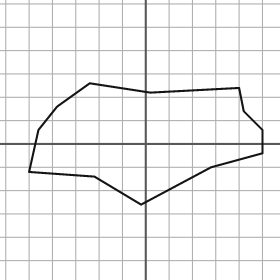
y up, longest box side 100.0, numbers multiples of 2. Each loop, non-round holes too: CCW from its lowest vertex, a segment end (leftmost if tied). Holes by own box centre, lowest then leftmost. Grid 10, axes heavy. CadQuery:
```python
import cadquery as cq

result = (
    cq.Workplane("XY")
    .moveTo(-2.0, -26.0)
    .lineTo(28.0, -10.0)
    .lineTo(50.0, -4.0)
    .lineTo(50.0, 6.0)
    .lineTo(42.0, 14.0)
    .lineTo(40.0, 24.0)
    .lineTo(2.0, 22.0)
    .lineTo(-24.0, 26.0)
    .lineTo(-38.0, 16.0)
    .lineTo(-46.0, 6.0)
    .lineTo(-50.0, -12.0)
    .lineTo(-22.0, -14.0)
    .close()
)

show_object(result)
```